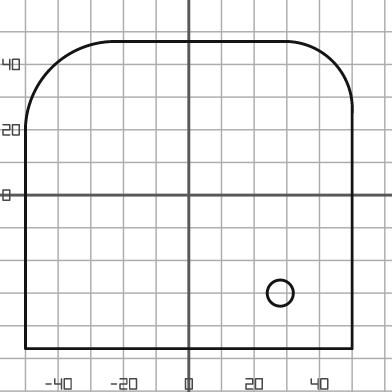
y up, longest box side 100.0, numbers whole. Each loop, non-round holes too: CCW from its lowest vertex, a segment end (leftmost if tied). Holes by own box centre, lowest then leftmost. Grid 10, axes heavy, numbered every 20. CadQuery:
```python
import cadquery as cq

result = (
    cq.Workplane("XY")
    .moveTo(-50.0, -47.0)
    .lineTo(50.0, -47.0)
    .lineTo(50.0, 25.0)
    .threePointArc((44.0, 41.0), (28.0, 47.0))
    .lineTo(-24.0, 47.0)
    .threePointArc((-42.0, 39.0), (-50.0, 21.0))
    .close()
    .moveTo(28.0, -30.0)
    .circle(4.0)
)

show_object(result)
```